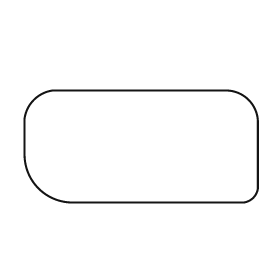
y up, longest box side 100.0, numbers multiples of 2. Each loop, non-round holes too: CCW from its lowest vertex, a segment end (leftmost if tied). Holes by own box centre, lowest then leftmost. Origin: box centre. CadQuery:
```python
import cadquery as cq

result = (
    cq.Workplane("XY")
    .moveTo(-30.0, -24.0)
    .lineTo(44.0, -24.0)
    .threePointArc((48.0, -22.0), (50.0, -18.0))
    .lineTo(50.0, 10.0)
    .threePointArc((46.0, 20.0), (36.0, 24.0))
    .lineTo(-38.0, 24.0)
    .threePointArc((-46.0, 20.0), (-50.0, 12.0))
    .lineTo(-50.0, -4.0)
    .threePointArc((-44.0, -18.0), (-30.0, -24.0))
    .close()
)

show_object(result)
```